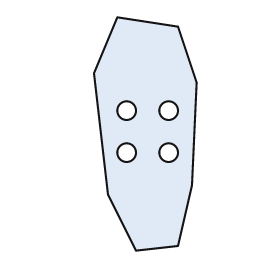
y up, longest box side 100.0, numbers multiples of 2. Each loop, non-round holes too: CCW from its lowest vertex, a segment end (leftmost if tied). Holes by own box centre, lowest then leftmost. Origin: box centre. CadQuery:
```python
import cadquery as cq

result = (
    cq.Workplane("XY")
    .moveTo(-4.0, -50.0)
    .lineTo(14.0, -48.0)
    .lineTo(20.0, -22.0)
    .lineTo(22.0, 22.0)
    .lineTo(14.0, 46.0)
    .lineTo(-12.0, 50.0)
    .lineTo(-22.0, 26.0)
    .lineTo(-16.0, -26.0)
    .close()
    .moveTo(-8.0, -8.0)
    .circle(4.0)
    .moveTo(10.0, -8.0)
    .circle(4.0)
    .moveTo(-8.0, 10.0)
    .circle(4.0)
    .moveTo(10.0, 10.0)
    .circle(4.0)
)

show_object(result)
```